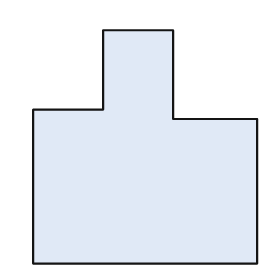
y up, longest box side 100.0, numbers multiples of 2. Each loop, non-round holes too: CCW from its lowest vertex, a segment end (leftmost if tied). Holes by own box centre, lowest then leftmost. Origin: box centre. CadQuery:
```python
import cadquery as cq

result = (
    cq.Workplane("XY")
    .moveTo(-48.0, -50.0)
    .lineTo(48.0, -50.0)
    .lineTo(48.0, 12.0)
    .lineTo(12.0, 12.0)
    .lineTo(12.0, 50.0)
    .lineTo(-18.0, 50.0)
    .lineTo(-18.0, 16.0)
    .lineTo(-48.0, 16.0)
    .close()
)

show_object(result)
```